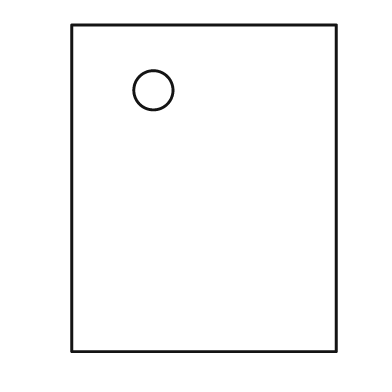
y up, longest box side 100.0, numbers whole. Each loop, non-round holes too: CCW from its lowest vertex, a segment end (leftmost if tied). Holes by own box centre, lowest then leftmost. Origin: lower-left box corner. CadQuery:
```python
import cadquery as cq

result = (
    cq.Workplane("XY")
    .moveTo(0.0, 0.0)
    .lineTo(81.0, 0.0)
    .lineTo(81.0, 100.0)
    .lineTo(0.0, 100.0)
    .close()
    .moveTo(25.0, 80.0)
    .circle(6.0)
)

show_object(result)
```